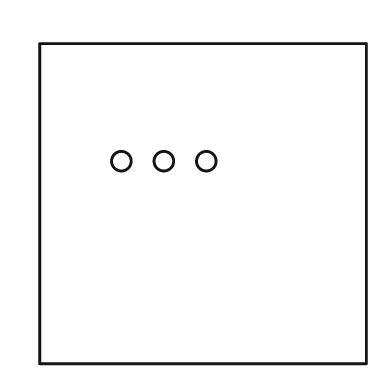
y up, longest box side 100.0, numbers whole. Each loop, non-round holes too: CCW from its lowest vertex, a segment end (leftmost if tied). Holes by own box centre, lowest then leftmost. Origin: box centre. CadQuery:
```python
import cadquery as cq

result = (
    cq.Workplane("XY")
    .moveTo(-50.0, -49.0)
    .lineTo(50.0, -49.0)
    .lineTo(50.0, 49.0)
    .lineTo(-50.0, 49.0)
    .close()
    .moveTo(-25.0, 13.0)
    .circle(3.0)
    .moveTo(-12.0, 13.0)
    .circle(3.0)
    .moveTo(1.0, 13.0)
    .circle(3.0)
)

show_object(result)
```